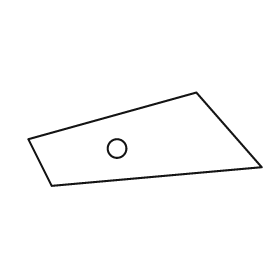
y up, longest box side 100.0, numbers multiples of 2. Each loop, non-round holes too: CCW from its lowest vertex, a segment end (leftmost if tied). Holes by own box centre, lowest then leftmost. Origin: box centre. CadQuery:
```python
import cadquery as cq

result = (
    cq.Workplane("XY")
    .moveTo(-40.0, -20.0)
    .lineTo(50.0, -12.0)
    .lineTo(22.0, 20.0)
    .lineTo(-50.0, 0.0)
    .close()
    .moveTo(-12.0, -4.0)
    .circle(4.0)
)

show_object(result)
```